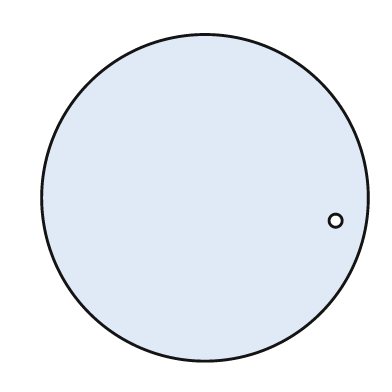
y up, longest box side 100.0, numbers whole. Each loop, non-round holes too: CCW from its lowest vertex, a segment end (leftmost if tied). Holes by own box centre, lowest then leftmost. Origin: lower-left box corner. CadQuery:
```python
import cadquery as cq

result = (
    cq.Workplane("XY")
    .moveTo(50.0, 50.0)
    .circle(50.0)
    .moveTo(90.0, 43.0)
    .circle(2.0)
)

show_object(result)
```